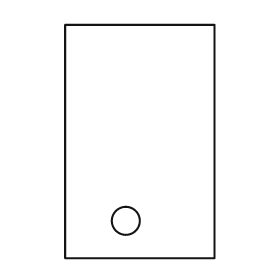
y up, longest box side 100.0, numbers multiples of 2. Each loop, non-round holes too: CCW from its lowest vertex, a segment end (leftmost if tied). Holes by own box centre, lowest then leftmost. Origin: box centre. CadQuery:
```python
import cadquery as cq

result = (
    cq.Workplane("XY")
    .moveTo(-32.0, -50.0)
    .lineTo(32.0, -50.0)
    .lineTo(32.0, 50.0)
    .lineTo(-32.0, 50.0)
    .close()
    .moveTo(-6.0, -34.0)
    .circle(6.0)
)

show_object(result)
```